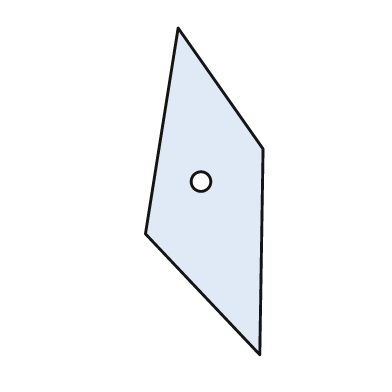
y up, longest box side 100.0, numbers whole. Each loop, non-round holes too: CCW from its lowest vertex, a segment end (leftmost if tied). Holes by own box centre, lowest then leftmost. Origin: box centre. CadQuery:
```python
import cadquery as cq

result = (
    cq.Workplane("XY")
    .moveTo(17.0, -50.0)
    .lineTo(18.0, 13.0)
    .lineTo(-8.0, 50.0)
    .lineTo(-18.0, -13.0)
    .close()
    .moveTo(-1.0, 3.0)
    .circle(3.0)
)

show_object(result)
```